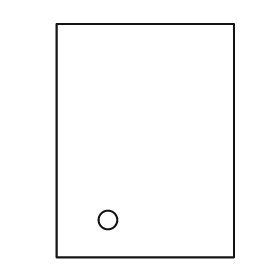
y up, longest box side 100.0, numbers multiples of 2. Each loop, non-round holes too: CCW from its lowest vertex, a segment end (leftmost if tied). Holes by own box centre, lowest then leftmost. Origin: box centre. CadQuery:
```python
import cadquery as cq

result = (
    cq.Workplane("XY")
    .moveTo(-38.0, -50.0)
    .lineTo(38.0, -50.0)
    .lineTo(38.0, 50.0)
    .lineTo(-38.0, 50.0)
    .close()
    .moveTo(-16.0, -34.0)
    .circle(4.0)
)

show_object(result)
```